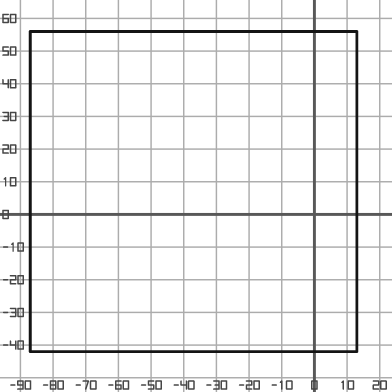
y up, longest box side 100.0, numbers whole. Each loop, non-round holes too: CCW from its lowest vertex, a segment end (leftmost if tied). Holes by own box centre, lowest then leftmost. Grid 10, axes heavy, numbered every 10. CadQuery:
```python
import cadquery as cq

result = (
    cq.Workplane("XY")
    .moveTo(-87.0, -42.0)
    .lineTo(13.0, -42.0)
    .lineTo(13.0, 56.0)
    .lineTo(-87.0, 56.0)
    .close()
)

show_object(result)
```